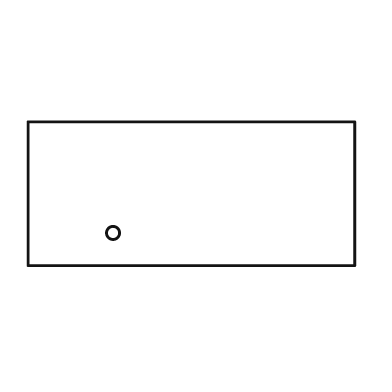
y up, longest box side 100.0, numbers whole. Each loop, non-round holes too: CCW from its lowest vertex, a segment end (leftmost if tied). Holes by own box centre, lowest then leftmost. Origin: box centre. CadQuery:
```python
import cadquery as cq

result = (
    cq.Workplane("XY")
    .moveTo(-50.0, -22.0)
    .lineTo(50.0, -22.0)
    .lineTo(50.0, 22.0)
    .lineTo(-50.0, 22.0)
    .close()
    .moveTo(-24.0, -12.0)
    .circle(2.0)
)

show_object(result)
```